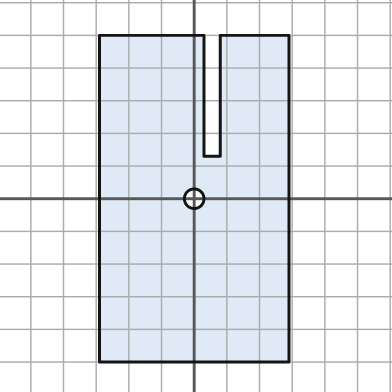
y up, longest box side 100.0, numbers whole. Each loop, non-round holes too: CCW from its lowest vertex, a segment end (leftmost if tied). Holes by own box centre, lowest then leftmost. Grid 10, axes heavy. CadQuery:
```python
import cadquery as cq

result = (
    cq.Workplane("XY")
    .moveTo(-29.0, -50.0)
    .lineTo(29.0, -50.0)
    .lineTo(29.0, 50.0)
    .lineTo(8.0, 50.0)
    .lineTo(8.0, 13.0)
    .lineTo(3.0, 13.0)
    .lineTo(3.0, 50.0)
    .lineTo(-29.0, 50.0)
    .close()
    .moveTo(0.0, 0.0)
    .circle(3.0)
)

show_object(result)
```